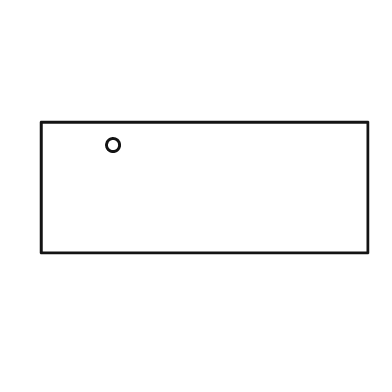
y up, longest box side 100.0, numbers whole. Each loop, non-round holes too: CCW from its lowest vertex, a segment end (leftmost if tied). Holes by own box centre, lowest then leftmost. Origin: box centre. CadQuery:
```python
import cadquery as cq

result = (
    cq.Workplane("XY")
    .moveTo(-50.0, -20.0)
    .lineTo(50.0, -20.0)
    .lineTo(50.0, 20.0)
    .lineTo(-50.0, 20.0)
    .close()
    .moveTo(-28.0, 13.0)
    .circle(2.0)
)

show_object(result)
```